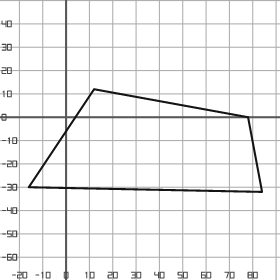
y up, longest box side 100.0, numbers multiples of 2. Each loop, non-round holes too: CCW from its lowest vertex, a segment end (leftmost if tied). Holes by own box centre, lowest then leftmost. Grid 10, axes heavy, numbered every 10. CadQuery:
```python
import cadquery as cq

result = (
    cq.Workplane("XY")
    .moveTo(84.0, -32.0)
    .lineTo(78.0, 0.0)
    .lineTo(12.0, 12.0)
    .lineTo(-16.0, -30.0)
    .close()
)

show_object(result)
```